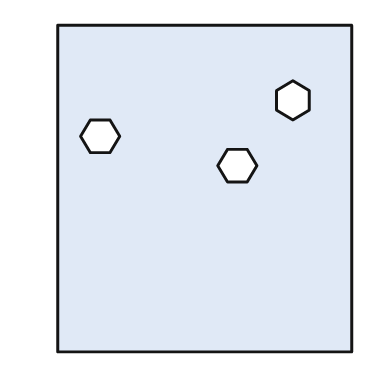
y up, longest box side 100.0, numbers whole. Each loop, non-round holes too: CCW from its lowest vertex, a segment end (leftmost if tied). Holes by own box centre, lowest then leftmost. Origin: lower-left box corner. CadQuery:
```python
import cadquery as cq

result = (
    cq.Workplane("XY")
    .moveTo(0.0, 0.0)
    .lineTo(90.0, 0.0)
    .lineTo(90.0, 100.0)
    .lineTo(0.0, 100.0)
    .close()
    .moveTo(52.0, 52.0)
    .lineTo(58.0, 52.0)
    .lineTo(61.0, 57.0)
    .lineTo(58.0, 62.0)
    .lineTo(52.0, 62.0)
    .lineTo(49.0, 57.0)
    .close()
    .moveTo(10.0, 61.0)
    .lineTo(16.0, 61.0)
    .lineTo(19.0, 66.0)
    .lineTo(16.0, 71.0)
    .lineTo(10.0, 71.0)
    .lineTo(7.0, 66.0)
    .close()
    .moveTo(72.0, 71.0)
    .lineTo(77.0, 74.0)
    .lineTo(77.0, 80.0)
    .lineTo(72.0, 83.0)
    .lineTo(67.0, 80.0)
    .lineTo(67.0, 74.0)
    .close()
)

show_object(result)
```